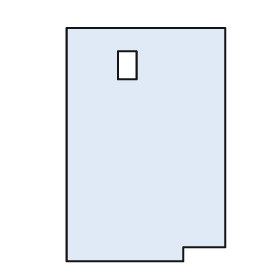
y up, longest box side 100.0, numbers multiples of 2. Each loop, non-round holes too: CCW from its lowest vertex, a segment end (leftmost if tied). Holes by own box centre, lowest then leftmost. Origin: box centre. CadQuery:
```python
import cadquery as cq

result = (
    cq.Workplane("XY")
    .moveTo(-34.0, -50.0)
    .lineTo(16.0, -50.0)
    .lineTo(16.0, -44.0)
    .lineTo(34.0, -44.0)
    .lineTo(34.0, 50.0)
    .lineTo(-34.0, 50.0)
    .close()
    .moveTo(-12.0, 28.0)
    .lineTo(-4.0, 28.0)
    .lineTo(-4.0, 40.0)
    .lineTo(-12.0, 40.0)
    .close()
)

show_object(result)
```